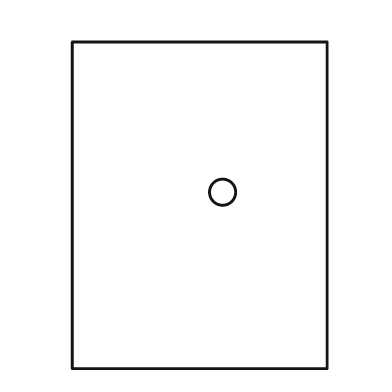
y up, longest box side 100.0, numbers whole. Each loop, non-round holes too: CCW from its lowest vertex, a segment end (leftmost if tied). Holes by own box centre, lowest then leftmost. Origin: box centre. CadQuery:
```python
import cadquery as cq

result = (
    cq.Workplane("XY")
    .moveTo(-39.0, -50.0)
    .lineTo(39.0, -50.0)
    .lineTo(39.0, 50.0)
    .lineTo(-39.0, 50.0)
    .close()
    .moveTo(7.0, 4.0)
    .circle(4.0)
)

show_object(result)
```